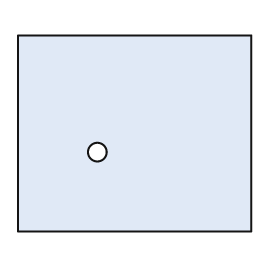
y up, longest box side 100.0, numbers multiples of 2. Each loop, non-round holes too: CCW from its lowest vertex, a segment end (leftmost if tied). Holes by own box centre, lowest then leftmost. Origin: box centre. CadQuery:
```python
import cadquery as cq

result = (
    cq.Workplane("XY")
    .moveTo(-50.0, -42.0)
    .lineTo(50.0, -42.0)
    .lineTo(50.0, 42.0)
    .lineTo(-50.0, 42.0)
    .close()
    .moveTo(-16.0, -8.0)
    .circle(4.0)
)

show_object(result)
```